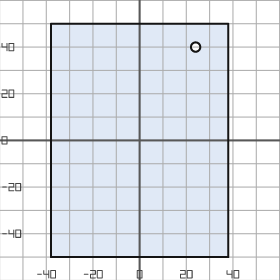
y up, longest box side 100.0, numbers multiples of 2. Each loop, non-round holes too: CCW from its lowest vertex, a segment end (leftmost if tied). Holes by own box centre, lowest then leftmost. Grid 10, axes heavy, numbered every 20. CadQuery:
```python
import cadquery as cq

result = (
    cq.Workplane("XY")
    .moveTo(-38.0, -50.0)
    .lineTo(38.0, -50.0)
    .lineTo(38.0, 50.0)
    .lineTo(-38.0, 50.0)
    .close()
    .moveTo(24.0, 40.0)
    .circle(2.0)
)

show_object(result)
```